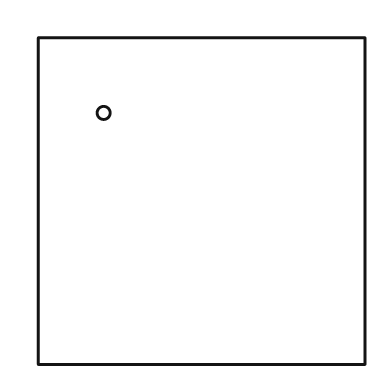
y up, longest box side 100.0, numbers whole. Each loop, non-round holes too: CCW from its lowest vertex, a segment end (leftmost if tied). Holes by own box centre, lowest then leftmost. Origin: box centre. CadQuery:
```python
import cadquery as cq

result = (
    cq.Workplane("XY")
    .moveTo(-50.0, -50.0)
    .lineTo(50.0, -50.0)
    .lineTo(50.0, 50.0)
    .lineTo(-50.0, 50.0)
    .close()
    .moveTo(-30.0, 27.0)
    .circle(2.0)
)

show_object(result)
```